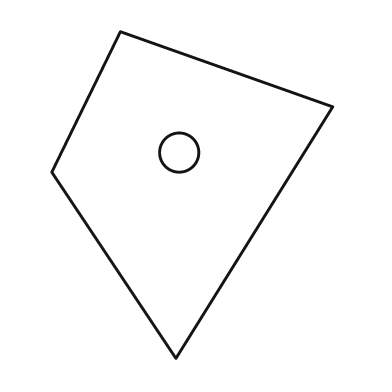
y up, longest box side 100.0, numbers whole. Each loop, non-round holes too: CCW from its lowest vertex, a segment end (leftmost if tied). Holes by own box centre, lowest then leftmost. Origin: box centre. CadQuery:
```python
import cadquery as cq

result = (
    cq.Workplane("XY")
    .moveTo(-5.0, -50.0)
    .lineTo(43.0, 27.0)
    .lineTo(-22.0, 50.0)
    .lineTo(-43.0, 7.0)
    .close()
    .moveTo(-4.0, 13.0)
    .circle(6.0)
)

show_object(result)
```